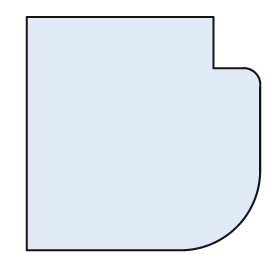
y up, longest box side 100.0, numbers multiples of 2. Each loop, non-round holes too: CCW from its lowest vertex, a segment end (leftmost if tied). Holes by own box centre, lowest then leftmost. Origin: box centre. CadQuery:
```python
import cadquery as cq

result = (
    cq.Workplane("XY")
    .moveTo(-50.0, -50.0)
    .lineTo(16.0, -50.0)
    .threePointArc((40.0, -40.0), (50.0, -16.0))
    .lineTo(50.0, 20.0)
    .threePointArc((48.0, 26.0), (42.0, 28.0))
    .lineTo(30.0, 28.0)
    .lineTo(30.0, 50.0)
    .lineTo(-50.0, 50.0)
    .close()
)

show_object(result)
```